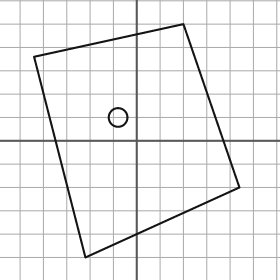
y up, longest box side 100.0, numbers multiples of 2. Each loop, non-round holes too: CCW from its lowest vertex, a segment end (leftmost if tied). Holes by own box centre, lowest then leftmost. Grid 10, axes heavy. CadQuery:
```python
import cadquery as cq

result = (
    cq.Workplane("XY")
    .moveTo(-22.0, -50.0)
    .lineTo(44.0, -20.0)
    .lineTo(20.0, 50.0)
    .lineTo(-44.0, 36.0)
    .close()
    .moveTo(-8.0, 10.0)
    .circle(4.0)
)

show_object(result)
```